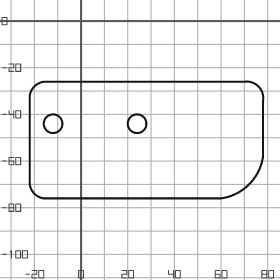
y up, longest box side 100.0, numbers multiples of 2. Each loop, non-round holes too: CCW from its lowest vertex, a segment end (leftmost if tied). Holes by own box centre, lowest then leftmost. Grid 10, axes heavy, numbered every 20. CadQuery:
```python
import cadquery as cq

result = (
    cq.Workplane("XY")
    .moveTo(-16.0, -76.0)
    .lineTo(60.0, -76.0)
    .threePointArc((72.0, -70.0), (78.0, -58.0))
    .lineTo(78.0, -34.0)
    .threePointArc((76.0, -28.0), (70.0, -26.0))
    .lineTo(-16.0, -26.0)
    .threePointArc((-20.0, -28.0), (-22.0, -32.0))
    .lineTo(-22.0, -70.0)
    .threePointArc((-20.0, -74.0), (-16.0, -76.0))
    .close()
    .moveTo(-12.0, -44.0)
    .circle(4.0)
    .moveTo(24.0, -44.0)
    .circle(4.0)
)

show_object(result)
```